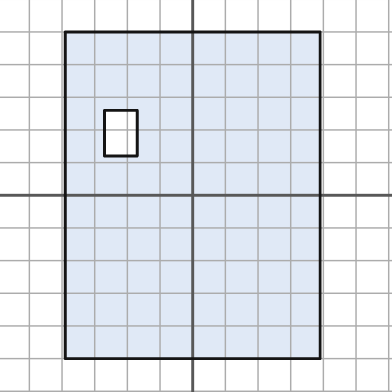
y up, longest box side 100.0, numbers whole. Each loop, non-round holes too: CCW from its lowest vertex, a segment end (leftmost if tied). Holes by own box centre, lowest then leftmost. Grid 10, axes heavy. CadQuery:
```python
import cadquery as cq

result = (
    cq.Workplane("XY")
    .moveTo(-39.0, -50.0)
    .lineTo(39.0, -50.0)
    .lineTo(39.0, 50.0)
    .lineTo(-39.0, 50.0)
    .close()
    .moveTo(-27.0, 12.0)
    .lineTo(-17.0, 12.0)
    .lineTo(-17.0, 26.0)
    .lineTo(-27.0, 26.0)
    .close()
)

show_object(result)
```